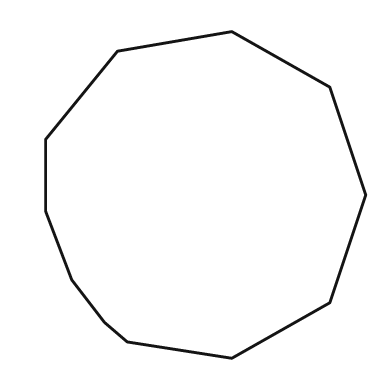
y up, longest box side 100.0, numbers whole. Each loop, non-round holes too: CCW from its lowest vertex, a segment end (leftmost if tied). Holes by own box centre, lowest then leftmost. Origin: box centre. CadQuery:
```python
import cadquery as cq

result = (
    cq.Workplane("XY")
    .moveTo(8.0, -50.0)
    .lineTo(38.0, -33.0)
    .lineTo(49.0, 0.0)
    .lineTo(38.0, 33.0)
    .lineTo(8.0, 50.0)
    .lineTo(-27.0, 44.0)
    .lineTo(-49.0, 17.0)
    .lineTo(-49.0, -5.0)
    .lineTo(-41.0, -26.0)
    .lineTo(-31.0, -39.0)
    .lineTo(-24.0, -45.0)
    .close()
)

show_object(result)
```